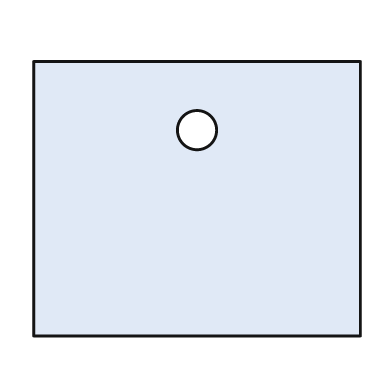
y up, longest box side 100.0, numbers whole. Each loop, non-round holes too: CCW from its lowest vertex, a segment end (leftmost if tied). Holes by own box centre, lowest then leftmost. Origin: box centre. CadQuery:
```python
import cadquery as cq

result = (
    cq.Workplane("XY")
    .moveTo(-50.0, -42.0)
    .lineTo(50.0, -42.0)
    .lineTo(50.0, 42.0)
    .lineTo(-50.0, 42.0)
    .close()
    .moveTo(0.0, 21.0)
    .circle(6.0)
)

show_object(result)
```